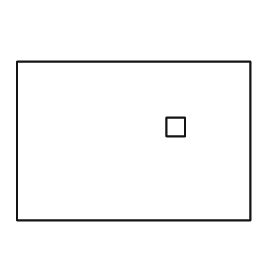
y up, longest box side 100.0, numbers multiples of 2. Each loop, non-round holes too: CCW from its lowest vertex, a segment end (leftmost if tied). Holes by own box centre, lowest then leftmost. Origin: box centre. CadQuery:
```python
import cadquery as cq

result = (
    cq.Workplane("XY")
    .moveTo(-50.0, -34.0)
    .lineTo(50.0, -34.0)
    .lineTo(50.0, 34.0)
    .lineTo(-50.0, 34.0)
    .close()
    .moveTo(14.0, 2.0)
    .lineTo(22.0, 2.0)
    .lineTo(22.0, 10.0)
    .lineTo(14.0, 10.0)
    .close()
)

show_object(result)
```